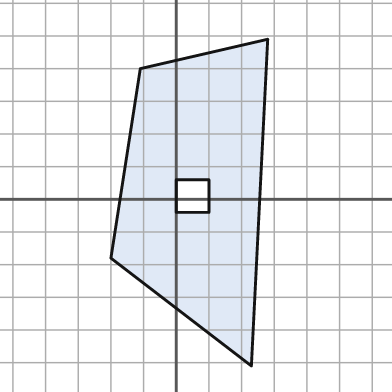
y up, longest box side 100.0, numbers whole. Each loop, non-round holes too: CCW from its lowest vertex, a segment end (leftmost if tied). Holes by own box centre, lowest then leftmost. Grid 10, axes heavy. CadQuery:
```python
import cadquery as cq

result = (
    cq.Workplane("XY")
    .moveTo(23.0, -51.0)
    .lineTo(28.0, 49.0)
    .lineTo(-11.0, 40.0)
    .lineTo(-20.0, -18.0)
    .close()
    .moveTo(0.0, -4.0)
    .lineTo(10.0, -4.0)
    .lineTo(10.0, 6.0)
    .lineTo(0.0, 6.0)
    .close()
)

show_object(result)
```